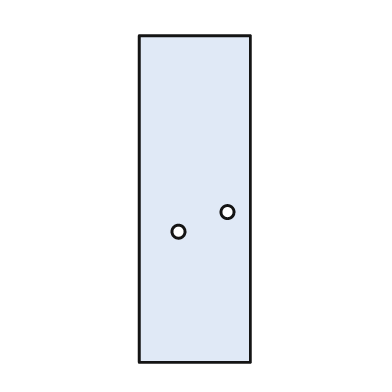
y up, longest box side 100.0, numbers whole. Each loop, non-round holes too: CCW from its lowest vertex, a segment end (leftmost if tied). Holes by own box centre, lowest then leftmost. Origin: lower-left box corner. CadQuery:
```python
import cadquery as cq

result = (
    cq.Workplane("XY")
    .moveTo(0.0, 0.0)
    .lineTo(34.0, 0.0)
    .lineTo(34.0, 100.0)
    .lineTo(0.0, 100.0)
    .close()
    .moveTo(12.0, 40.0)
    .circle(2.0)
    .moveTo(27.0, 46.0)
    .circle(2.0)
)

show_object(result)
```